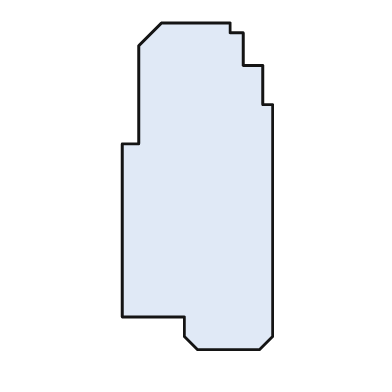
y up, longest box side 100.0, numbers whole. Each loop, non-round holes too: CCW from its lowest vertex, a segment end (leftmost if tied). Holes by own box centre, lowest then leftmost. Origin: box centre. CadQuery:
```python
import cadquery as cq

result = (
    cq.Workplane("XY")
    .moveTo(0.0, -50.0)
    .lineTo(19.0, -50.0)
    .lineTo(23.0, -46.0)
    .lineTo(23.0, 25.0)
    .lineTo(20.0, 25.0)
    .lineTo(20.0, 37.0)
    .lineTo(14.0, 37.0)
    .lineTo(14.0, 47.0)
    .lineTo(10.0, 47.0)
    .lineTo(10.0, 50.0)
    .lineTo(-11.0, 50.0)
    .lineTo(-18.0, 43.0)
    .lineTo(-18.0, 13.0)
    .lineTo(-23.0, 13.0)
    .lineTo(-23.0, -40.0)
    .lineTo(-4.0, -40.0)
    .lineTo(-4.0, -46.0)
    .close()
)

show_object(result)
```